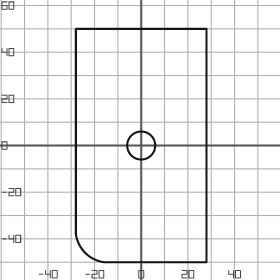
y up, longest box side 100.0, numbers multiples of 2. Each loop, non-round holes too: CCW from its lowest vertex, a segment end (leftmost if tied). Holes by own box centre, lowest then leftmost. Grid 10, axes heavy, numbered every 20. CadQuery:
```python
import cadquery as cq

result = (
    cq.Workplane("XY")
    .moveTo(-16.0, -50.0)
    .lineTo(28.0, -50.0)
    .lineTo(28.0, 50.0)
    .lineTo(-28.0, 50.0)
    .lineTo(-28.0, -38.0)
    .threePointArc((-24.0, -46.0), (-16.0, -50.0))
    .close()
    .moveTo(0.0, 0.0)
    .circle(6.0)
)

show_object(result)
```